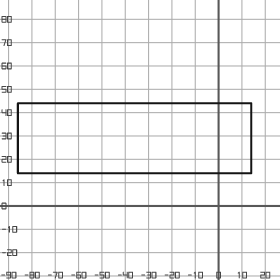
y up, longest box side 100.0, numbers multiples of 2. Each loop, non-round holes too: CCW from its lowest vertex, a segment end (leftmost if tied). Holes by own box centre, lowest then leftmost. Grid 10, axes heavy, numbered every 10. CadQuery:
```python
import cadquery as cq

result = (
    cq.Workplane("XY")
    .moveTo(-86.0, 14.0)
    .lineTo(14.0, 14.0)
    .lineTo(14.0, 44.0)
    .lineTo(-86.0, 44.0)
    .close()
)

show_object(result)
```